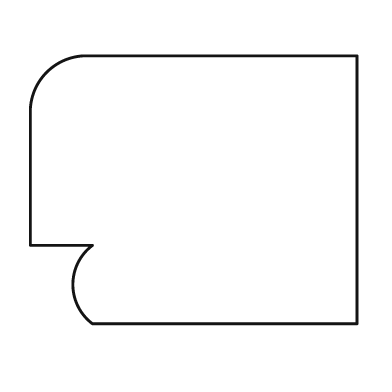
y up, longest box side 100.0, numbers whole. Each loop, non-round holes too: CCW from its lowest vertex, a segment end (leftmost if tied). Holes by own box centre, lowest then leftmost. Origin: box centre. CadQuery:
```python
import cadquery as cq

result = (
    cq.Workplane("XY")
    .moveTo(-31.0, -41.0)
    .lineTo(50.0, -41.0)
    .lineTo(50.0, 41.0)
    .lineTo(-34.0, 41.0)
    .threePointArc((-45.0, 36.0), (-50.0, 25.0))
    .lineTo(-50.0, -17.0)
    .lineTo(-31.0, -17.0)
    .threePointArc((-37.0, -29.0), (-31.0, -41.0))
    .close()
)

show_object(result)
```